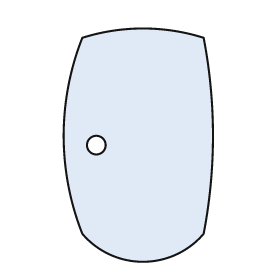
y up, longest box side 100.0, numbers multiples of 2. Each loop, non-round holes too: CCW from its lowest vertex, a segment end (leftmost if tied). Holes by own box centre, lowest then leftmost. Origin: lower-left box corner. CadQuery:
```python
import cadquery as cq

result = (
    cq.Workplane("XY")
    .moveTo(8.0, 12.0)
    .threePointArc((34.0, 0.0), (60.0, 12.0))
    .threePointArc((64.0, 54.0), (60.0, 96.0))
    .threePointArc((34.0, 100.0), (8.0, 96.0))
    .threePointArc((0.0, 54.0), (8.0, 12.0))
    .close()
    .moveTo(14.0, 50.0)
    .circle(4.0)
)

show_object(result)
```